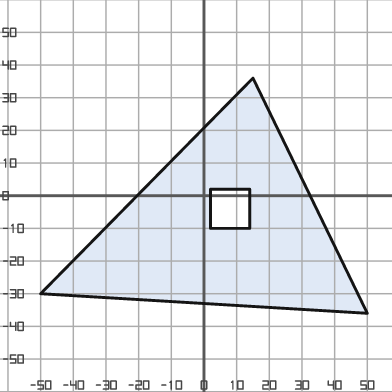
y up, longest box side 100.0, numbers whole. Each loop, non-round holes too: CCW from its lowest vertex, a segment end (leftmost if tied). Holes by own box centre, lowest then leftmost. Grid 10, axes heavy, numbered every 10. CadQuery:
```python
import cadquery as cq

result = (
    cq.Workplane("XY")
    .moveTo(50.0, -36.0)
    .lineTo(15.0, 36.0)
    .lineTo(-50.0, -30.0)
    .close()
    .moveTo(2.0, -10.0)
    .lineTo(14.0, -10.0)
    .lineTo(14.0, 2.0)
    .lineTo(2.0, 2.0)
    .close()
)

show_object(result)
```